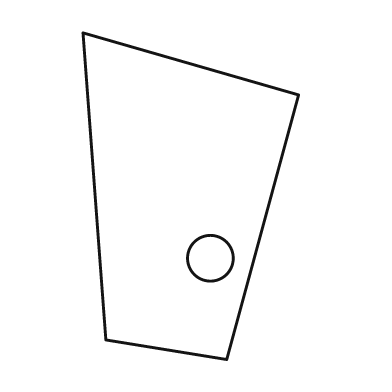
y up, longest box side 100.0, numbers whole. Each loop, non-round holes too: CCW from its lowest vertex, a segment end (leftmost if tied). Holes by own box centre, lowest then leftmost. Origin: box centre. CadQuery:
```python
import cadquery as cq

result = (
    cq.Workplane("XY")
    .moveTo(11.0, -50.0)
    .lineTo(33.0, 31.0)
    .lineTo(-33.0, 50.0)
    .lineTo(-26.0, -44.0)
    .close()
    .moveTo(6.0, -19.0)
    .circle(7.0)
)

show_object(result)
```